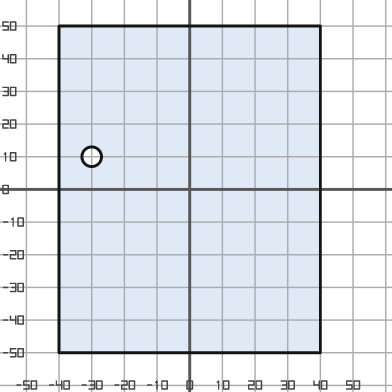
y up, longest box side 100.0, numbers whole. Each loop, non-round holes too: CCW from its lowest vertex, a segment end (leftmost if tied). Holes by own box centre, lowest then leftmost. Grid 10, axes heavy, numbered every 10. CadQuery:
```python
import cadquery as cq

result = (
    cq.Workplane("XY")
    .moveTo(-40.0, -50.0)
    .lineTo(40.0, -50.0)
    .lineTo(40.0, 50.0)
    .lineTo(-40.0, 50.0)
    .close()
    .moveTo(-30.0, 10.0)
    .circle(3.0)
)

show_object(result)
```